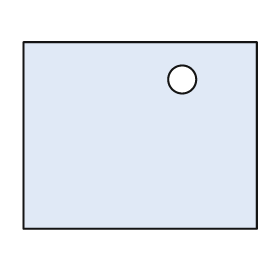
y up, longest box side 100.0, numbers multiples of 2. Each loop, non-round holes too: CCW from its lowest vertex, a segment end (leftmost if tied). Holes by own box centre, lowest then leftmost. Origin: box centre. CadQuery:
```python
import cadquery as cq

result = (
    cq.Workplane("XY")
    .moveTo(-50.0, -40.0)
    .lineTo(50.0, -40.0)
    .lineTo(50.0, 40.0)
    .lineTo(-50.0, 40.0)
    .close()
    .moveTo(18.0, 24.0)
    .circle(6.0)
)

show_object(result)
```